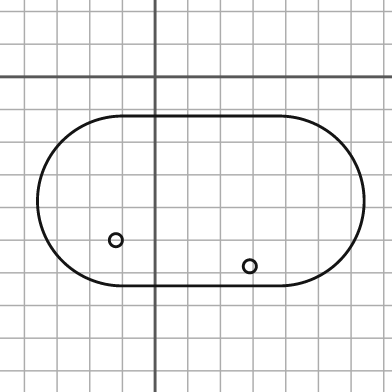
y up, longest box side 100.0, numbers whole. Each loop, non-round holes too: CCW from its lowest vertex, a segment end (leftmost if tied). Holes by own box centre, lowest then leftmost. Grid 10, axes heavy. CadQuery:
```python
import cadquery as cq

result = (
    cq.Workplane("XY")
    .moveTo(-10.0, -64.0)
    .lineTo(38.0, -64.0)
    .threePointArc((64.0, -38.0), (38.0, -12.0))
    .lineTo(-10.0, -12.0)
    .threePointArc((-36.0, -38.0), (-10.0, -64.0))
    .close()
    .moveTo(29.0, -58.0)
    .circle(2.0)
    .moveTo(-12.0, -50.0)
    .circle(2.0)
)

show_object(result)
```